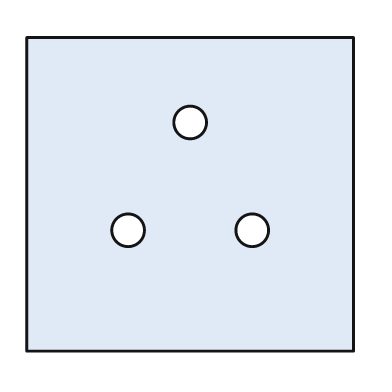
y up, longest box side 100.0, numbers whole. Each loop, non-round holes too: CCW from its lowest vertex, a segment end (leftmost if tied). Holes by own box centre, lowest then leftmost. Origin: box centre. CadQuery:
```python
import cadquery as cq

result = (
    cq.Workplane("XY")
    .moveTo(-50.0, -48.0)
    .lineTo(50.0, -48.0)
    .lineTo(50.0, 48.0)
    .lineTo(-50.0, 48.0)
    .close()
    .moveTo(-19.0, -11.0)
    .circle(5.0)
    .moveTo(19.0, -11.0)
    .circle(5.0)
    .moveTo(0.0, 22.0)
    .circle(5.0)
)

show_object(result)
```